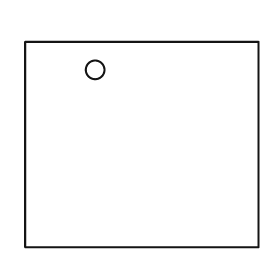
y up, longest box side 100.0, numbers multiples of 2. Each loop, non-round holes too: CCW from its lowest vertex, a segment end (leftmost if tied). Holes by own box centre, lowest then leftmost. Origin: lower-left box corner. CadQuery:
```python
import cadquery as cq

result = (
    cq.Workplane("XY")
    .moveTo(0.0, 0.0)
    .lineTo(100.0, 0.0)
    .lineTo(100.0, 88.0)
    .lineTo(0.0, 88.0)
    .close()
    .moveTo(30.0, 76.0)
    .circle(4.0)
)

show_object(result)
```